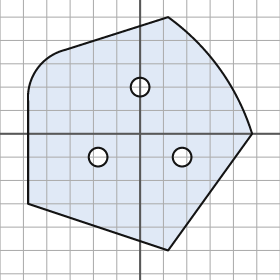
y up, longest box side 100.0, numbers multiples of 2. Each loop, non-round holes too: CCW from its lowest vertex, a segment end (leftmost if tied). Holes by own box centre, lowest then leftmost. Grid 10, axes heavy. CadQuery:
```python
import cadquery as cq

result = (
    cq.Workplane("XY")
    .moveTo(12.0, -50.0)
    .lineTo(48.0, 0.0)
    .threePointArc((34.0, 28.0), (12.0, 50.0))
    .lineTo(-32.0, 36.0)
    .threePointArc((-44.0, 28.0), (-48.0, 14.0))
    .lineTo(-48.0, -30.0)
    .close()
    .moveTo(-18.0, -10.0)
    .circle(4.0)
    .moveTo(18.0, -10.0)
    .circle(4.0)
    .moveTo(0.0, 20.0)
    .circle(4.0)
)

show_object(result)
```